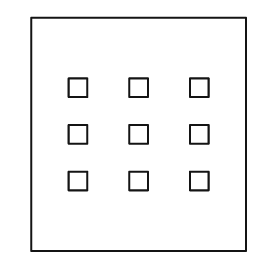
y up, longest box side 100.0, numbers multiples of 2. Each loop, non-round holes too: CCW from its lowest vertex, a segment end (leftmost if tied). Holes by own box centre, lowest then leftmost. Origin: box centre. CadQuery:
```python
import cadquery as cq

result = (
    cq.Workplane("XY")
    .moveTo(-46.0, -50.0)
    .lineTo(46.0, -50.0)
    .lineTo(46.0, 50.0)
    .lineTo(-46.0, 50.0)
    .close()
    .moveTo(-30.0, -24.0)
    .lineTo(-22.0, -24.0)
    .lineTo(-22.0, -16.0)
    .lineTo(-30.0, -16.0)
    .close()
    .moveTo(-4.0, -24.0)
    .lineTo(4.0, -24.0)
    .lineTo(4.0, -16.0)
    .lineTo(-4.0, -16.0)
    .close()
    .moveTo(22.0, -24.0)
    .lineTo(30.0, -24.0)
    .lineTo(30.0, -16.0)
    .lineTo(22.0, -16.0)
    .close()
    .moveTo(-30.0, -4.0)
    .lineTo(-22.0, -4.0)
    .lineTo(-22.0, 4.0)
    .lineTo(-30.0, 4.0)
    .close()
    .moveTo(-4.0, -4.0)
    .lineTo(4.0, -4.0)
    .lineTo(4.0, 4.0)
    .lineTo(-4.0, 4.0)
    .close()
    .moveTo(22.0, -4.0)
    .lineTo(30.0, -4.0)
    .lineTo(30.0, 4.0)
    .lineTo(22.0, 4.0)
    .close()
    .moveTo(-30.0, 16.0)
    .lineTo(-22.0, 16.0)
    .lineTo(-22.0, 24.0)
    .lineTo(-30.0, 24.0)
    .close()
    .moveTo(-4.0, 16.0)
    .lineTo(4.0, 16.0)
    .lineTo(4.0, 24.0)
    .lineTo(-4.0, 24.0)
    .close()
    .moveTo(22.0, 16.0)
    .lineTo(30.0, 16.0)
    .lineTo(30.0, 24.0)
    .lineTo(22.0, 24.0)
    .close()
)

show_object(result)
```